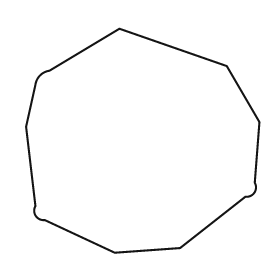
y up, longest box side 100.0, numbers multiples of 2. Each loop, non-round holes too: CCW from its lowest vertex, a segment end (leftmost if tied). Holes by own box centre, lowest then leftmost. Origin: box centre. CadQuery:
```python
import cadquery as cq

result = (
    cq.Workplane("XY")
    .moveTo(-12.0, -48.0)
    .lineTo(16.0, -46.0)
    .lineTo(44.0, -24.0)
    .threePointArc((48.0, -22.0), (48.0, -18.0))
    .lineTo(50.0, 8.0)
    .lineTo(36.0, 32.0)
    .lineTo(-10.0, 48.0)
    .lineTo(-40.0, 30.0)
    .threePointArc((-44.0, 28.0), (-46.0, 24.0))
    .lineTo(-50.0, 6.0)
    .lineTo(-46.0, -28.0)
    .threePointArc((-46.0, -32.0), (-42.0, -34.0))
    .close()
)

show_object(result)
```